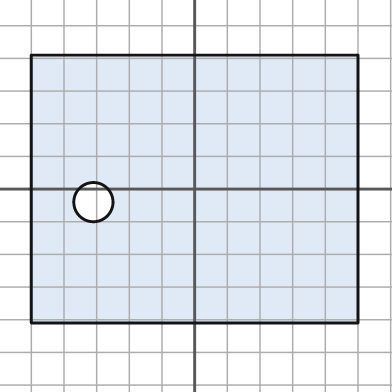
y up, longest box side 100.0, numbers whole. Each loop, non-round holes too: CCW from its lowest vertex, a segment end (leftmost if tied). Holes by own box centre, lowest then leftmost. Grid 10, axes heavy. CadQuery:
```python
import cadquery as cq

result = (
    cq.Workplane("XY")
    .moveTo(-50.0, -41.0)
    .lineTo(50.0, -41.0)
    .lineTo(50.0, 41.0)
    .lineTo(-50.0, 41.0)
    .close()
    .moveTo(-31.0, -4.0)
    .circle(6.0)
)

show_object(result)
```